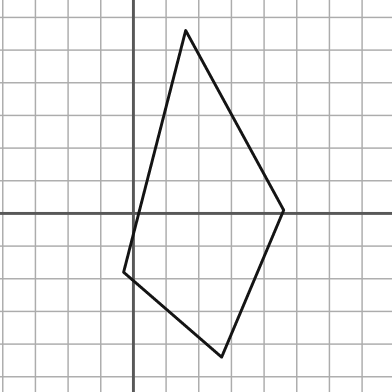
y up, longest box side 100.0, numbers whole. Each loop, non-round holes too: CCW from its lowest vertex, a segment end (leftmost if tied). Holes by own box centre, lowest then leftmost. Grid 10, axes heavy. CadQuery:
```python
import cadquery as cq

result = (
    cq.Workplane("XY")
    .moveTo(27.0, -44.0)
    .lineTo(46.0, 1.0)
    .lineTo(16.0, 56.0)
    .lineTo(-3.0, -18.0)
    .close()
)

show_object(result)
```